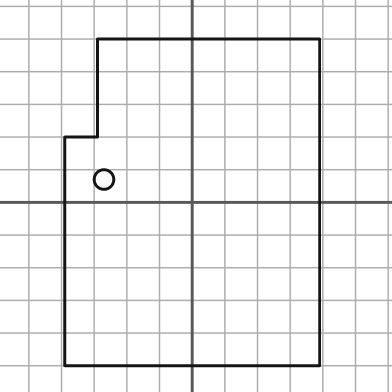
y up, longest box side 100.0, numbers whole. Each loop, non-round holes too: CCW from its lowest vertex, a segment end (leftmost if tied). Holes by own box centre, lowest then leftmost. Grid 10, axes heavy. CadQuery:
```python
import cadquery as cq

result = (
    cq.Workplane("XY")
    .moveTo(-39.0, -50.0)
    .lineTo(39.0, -50.0)
    .lineTo(39.0, 50.0)
    .lineTo(-29.0, 50.0)
    .lineTo(-29.0, 20.0)
    .lineTo(-39.0, 20.0)
    .close()
    .moveTo(-27.0, 7.0)
    .circle(3.0)
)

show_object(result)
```